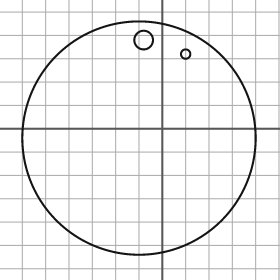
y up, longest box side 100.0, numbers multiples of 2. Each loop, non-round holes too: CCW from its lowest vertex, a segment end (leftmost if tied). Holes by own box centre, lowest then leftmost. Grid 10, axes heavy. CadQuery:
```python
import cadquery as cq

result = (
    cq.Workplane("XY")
    .moveTo(-10.0, -4.0)
    .circle(50.0)
    .moveTo(10.0, 32.0)
    .circle(2.0)
    .moveTo(-8.0, 38.0)
    .circle(4.0)
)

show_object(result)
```